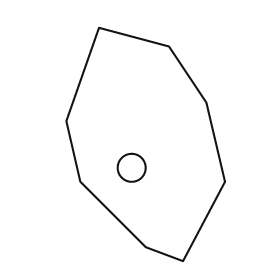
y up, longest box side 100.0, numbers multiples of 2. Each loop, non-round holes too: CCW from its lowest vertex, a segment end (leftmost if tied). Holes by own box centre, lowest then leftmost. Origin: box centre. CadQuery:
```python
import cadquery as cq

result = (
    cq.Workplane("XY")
    .moveTo(16.0, -50.0)
    .lineTo(34.0, -16.0)
    .lineTo(26.0, 18.0)
    .lineTo(10.0, 42.0)
    .lineTo(-20.0, 50.0)
    .lineTo(-34.0, 10.0)
    .lineTo(-28.0, -16.0)
    .lineTo(0.0, -44.0)
    .close()
    .moveTo(-6.0, -10.0)
    .circle(6.0)
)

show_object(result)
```